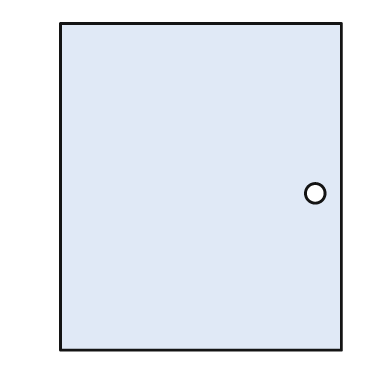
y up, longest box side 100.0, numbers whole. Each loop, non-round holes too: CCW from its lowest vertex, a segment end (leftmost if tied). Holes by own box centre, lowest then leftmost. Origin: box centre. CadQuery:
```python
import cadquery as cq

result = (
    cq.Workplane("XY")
    .moveTo(-43.0, -50.0)
    .lineTo(43.0, -50.0)
    .lineTo(43.0, 50.0)
    .lineTo(-43.0, 50.0)
    .close()
    .moveTo(35.0, -2.0)
    .circle(3.0)
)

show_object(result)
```